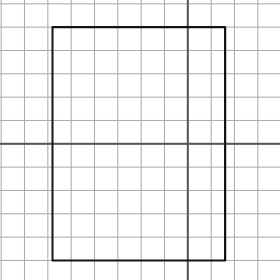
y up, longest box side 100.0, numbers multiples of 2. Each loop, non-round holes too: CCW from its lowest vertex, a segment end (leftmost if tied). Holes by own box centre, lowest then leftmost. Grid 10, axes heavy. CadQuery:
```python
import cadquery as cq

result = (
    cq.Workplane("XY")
    .moveTo(-58.0, -50.0)
    .lineTo(16.0, -50.0)
    .lineTo(16.0, 50.0)
    .lineTo(-58.0, 50.0)
    .close()
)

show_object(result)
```